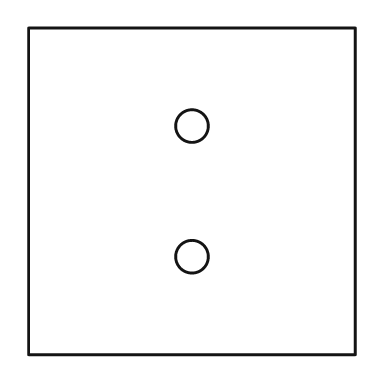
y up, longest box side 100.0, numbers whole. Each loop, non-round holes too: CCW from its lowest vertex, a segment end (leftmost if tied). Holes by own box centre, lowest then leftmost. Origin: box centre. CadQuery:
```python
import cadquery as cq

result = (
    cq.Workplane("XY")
    .moveTo(-50.0, -50.0)
    .lineTo(50.0, -50.0)
    .lineTo(50.0, 50.0)
    .lineTo(-50.0, 50.0)
    .close()
    .moveTo(0.0, -20.0)
    .circle(5.0)
    .moveTo(0.0, 20.0)
    .circle(5.0)
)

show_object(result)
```